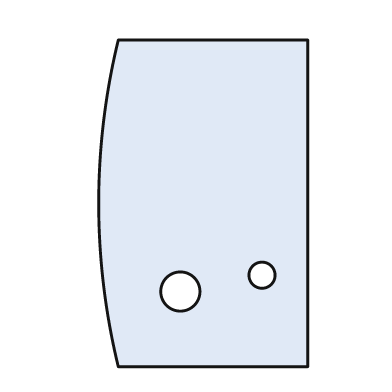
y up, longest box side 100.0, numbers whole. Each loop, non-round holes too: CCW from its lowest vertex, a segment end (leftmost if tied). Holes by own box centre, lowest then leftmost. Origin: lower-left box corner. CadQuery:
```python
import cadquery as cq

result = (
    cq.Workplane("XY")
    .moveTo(6.0, 0.0)
    .lineTo(64.0, 0.0)
    .lineTo(64.0, 100.0)
    .lineTo(6.0, 100.0)
    .threePointArc((0.0, 50.0), (6.0, 0.0))
    .close()
    .moveTo(25.0, 23.0)
    .circle(6.0)
    .moveTo(50.0, 28.0)
    .circle(4.0)
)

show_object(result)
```